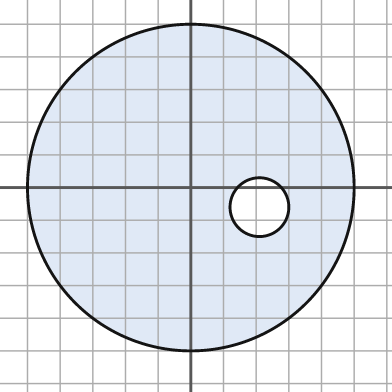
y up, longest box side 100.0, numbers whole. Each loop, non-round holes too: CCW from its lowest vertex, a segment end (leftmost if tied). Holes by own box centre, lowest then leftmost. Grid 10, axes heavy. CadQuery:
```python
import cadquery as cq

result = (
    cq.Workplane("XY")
    .moveTo(0.0, 0.0)
    .circle(50.0)
    .moveTo(21.0, -6.0)
    .circle(9.0)
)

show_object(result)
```